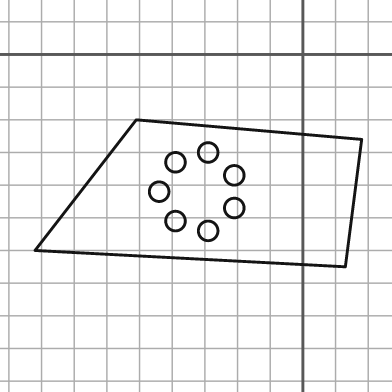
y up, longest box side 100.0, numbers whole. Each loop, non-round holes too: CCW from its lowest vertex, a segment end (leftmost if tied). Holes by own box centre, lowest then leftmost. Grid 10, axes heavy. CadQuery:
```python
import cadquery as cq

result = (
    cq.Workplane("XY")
    .moveTo(13.0, -65.0)
    .lineTo(18.0, -26.0)
    .lineTo(-51.0, -20.0)
    .lineTo(-82.0, -60.0)
    .close()
    .moveTo(-29.0, -54.0)
    .circle(3.0)
    .moveTo(-39.0, -51.0)
    .circle(3.0)
    .moveTo(-21.0, -47.0)
    .circle(3.0)
    .moveTo(-44.0, -42.0)
    .circle(3.0)
    .moveTo(-21.0, -37.0)
    .circle(3.0)
    .moveTo(-39.0, -33.0)
    .circle(3.0)
    .moveTo(-29.0, -30.0)
    .circle(3.0)
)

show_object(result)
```